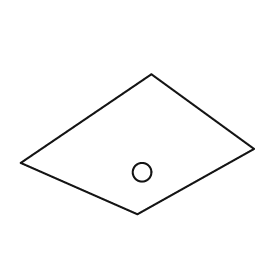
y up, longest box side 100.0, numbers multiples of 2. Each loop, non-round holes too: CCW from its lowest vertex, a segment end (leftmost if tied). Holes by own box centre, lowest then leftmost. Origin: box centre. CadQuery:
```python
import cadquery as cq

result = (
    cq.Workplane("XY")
    .moveTo(0.0, -30.0)
    .lineTo(50.0, -2.0)
    .lineTo(6.0, 30.0)
    .lineTo(-50.0, -8.0)
    .close()
    .moveTo(2.0, -12.0)
    .circle(4.0)
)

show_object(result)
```